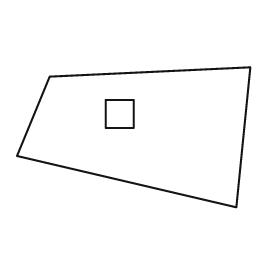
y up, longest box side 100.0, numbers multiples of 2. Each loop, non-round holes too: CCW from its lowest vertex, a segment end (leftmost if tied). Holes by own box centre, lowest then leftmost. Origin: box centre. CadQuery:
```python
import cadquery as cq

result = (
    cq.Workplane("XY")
    .moveTo(44.0, -30.0)
    .lineTo(50.0, 30.0)
    .lineTo(-36.0, 26.0)
    .lineTo(-50.0, -8.0)
    .close()
    .moveTo(-12.0, 4.0)
    .lineTo(0.0, 4.0)
    .lineTo(0.0, 16.0)
    .lineTo(-12.0, 16.0)
    .close()
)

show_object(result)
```